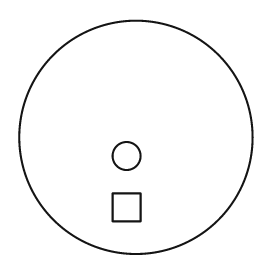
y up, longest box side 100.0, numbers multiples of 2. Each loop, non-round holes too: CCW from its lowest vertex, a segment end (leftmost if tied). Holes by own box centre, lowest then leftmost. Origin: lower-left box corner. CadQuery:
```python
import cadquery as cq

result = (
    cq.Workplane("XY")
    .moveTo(50.0, 50.0)
    .circle(50.0)
    .moveTo(40.0, 14.0)
    .lineTo(52.0, 14.0)
    .lineTo(52.0, 26.0)
    .lineTo(40.0, 26.0)
    .close()
    .moveTo(46.0, 42.0)
    .circle(6.0)
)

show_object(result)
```